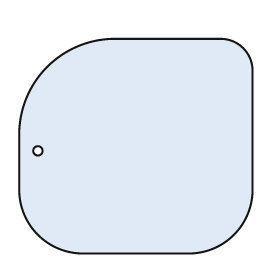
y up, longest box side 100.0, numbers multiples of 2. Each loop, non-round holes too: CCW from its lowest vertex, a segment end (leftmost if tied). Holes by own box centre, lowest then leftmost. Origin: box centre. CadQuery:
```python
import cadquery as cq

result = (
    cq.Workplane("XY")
    .moveTo(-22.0, -46.0)
    .lineTo(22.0, -46.0)
    .threePointArc((42.0, -38.0), (50.0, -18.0))
    .lineTo(50.0, 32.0)
    .threePointArc((46.0, 42.0), (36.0, 46.0))
    .lineTo(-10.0, 46.0)
    .threePointArc((-38.0, 34.0), (-50.0, 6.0))
    .lineTo(-50.0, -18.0)
    .threePointArc((-42.0, -38.0), (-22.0, -46.0))
    .close()
    .moveTo(-42.0, -2.0)
    .circle(2.0)
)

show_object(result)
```